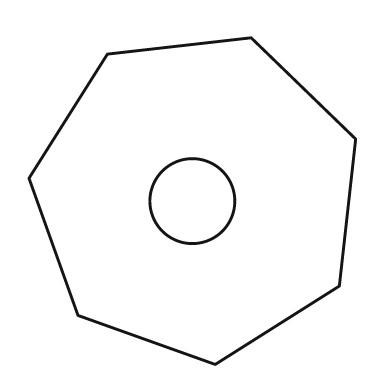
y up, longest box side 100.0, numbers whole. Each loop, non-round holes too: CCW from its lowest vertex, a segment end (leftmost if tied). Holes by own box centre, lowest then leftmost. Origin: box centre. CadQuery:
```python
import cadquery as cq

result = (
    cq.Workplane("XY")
    .moveTo(7.0, -50.0)
    .lineTo(45.0, -26.0)
    .lineTo(50.0, 19.0)
    .lineTo(18.0, 50.0)
    .lineTo(-26.0, 45.0)
    .lineTo(-50.0, 7.0)
    .lineTo(-35.0, -35.0)
    .close()
    .moveTo(0.0, 0.0)
    .circle(13.0)
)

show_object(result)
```